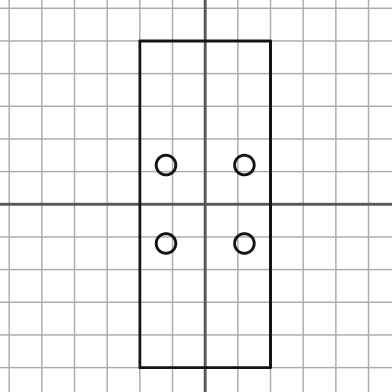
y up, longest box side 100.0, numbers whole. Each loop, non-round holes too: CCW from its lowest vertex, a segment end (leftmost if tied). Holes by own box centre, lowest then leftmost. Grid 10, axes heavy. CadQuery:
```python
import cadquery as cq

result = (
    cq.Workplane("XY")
    .moveTo(-20.0, -50.0)
    .lineTo(20.0, -50.0)
    .lineTo(20.0, 50.0)
    .lineTo(-20.0, 50.0)
    .close()
    .moveTo(-12.0, -12.0)
    .circle(3.0)
    .moveTo(12.0, -12.0)
    .circle(3.0)
    .moveTo(-12.0, 12.0)
    .circle(3.0)
    .moveTo(12.0, 12.0)
    .circle(3.0)
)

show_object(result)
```